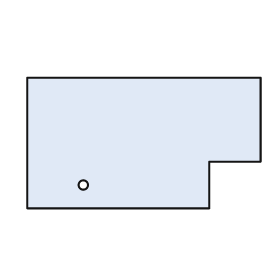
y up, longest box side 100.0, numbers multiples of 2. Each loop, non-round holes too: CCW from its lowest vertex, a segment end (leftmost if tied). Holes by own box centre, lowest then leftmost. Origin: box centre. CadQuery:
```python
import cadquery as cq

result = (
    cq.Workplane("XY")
    .moveTo(-50.0, -28.0)
    .lineTo(28.0, -28.0)
    .lineTo(28.0, -8.0)
    .lineTo(50.0, -8.0)
    .lineTo(50.0, 28.0)
    .lineTo(-50.0, 28.0)
    .close()
    .moveTo(-26.0, -18.0)
    .circle(2.0)
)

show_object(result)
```